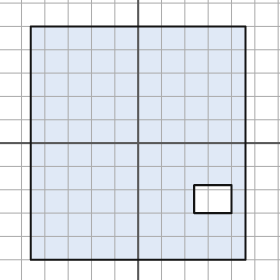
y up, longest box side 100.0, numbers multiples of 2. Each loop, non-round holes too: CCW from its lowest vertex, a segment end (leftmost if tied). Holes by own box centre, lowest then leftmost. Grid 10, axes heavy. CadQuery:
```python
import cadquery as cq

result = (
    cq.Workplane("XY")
    .moveTo(-46.0, -50.0)
    .lineTo(46.0, -50.0)
    .lineTo(46.0, 50.0)
    .lineTo(-46.0, 50.0)
    .close()
    .moveTo(24.0, -30.0)
    .lineTo(40.0, -30.0)
    .lineTo(40.0, -18.0)
    .lineTo(24.0, -18.0)
    .close()
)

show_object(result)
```